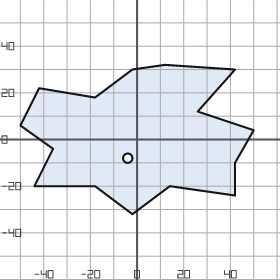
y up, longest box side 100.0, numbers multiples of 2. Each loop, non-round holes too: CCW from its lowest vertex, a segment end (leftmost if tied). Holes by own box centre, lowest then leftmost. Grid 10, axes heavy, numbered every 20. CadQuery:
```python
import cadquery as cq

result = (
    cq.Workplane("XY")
    .moveTo(-2.0, -32.0)
    .lineTo(14.0, -20.0)
    .lineTo(42.0, -24.0)
    .lineTo(42.0, -10.0)
    .lineTo(50.0, 4.0)
    .lineTo(26.0, 12.0)
    .lineTo(42.0, 30.0)
    .lineTo(12.0, 32.0)
    .lineTo(-2.0, 30.0)
    .lineTo(-18.0, 18.0)
    .lineTo(-42.0, 22.0)
    .lineTo(-50.0, 6.0)
    .lineTo(-36.0, -4.0)
    .lineTo(-44.0, -20.0)
    .lineTo(-18.0, -20.0)
    .close()
    .moveTo(-4.0, -8.0)
    .circle(2.0)
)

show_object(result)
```